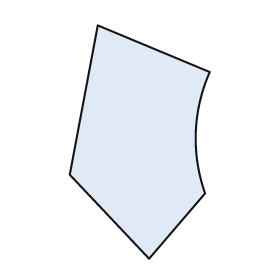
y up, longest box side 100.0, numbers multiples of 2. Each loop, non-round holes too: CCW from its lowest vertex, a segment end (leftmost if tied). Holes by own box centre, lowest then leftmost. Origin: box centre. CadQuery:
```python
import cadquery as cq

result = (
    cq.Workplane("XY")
    .moveTo(4.0, -50.0)
    .lineTo(28.0, -22.0)
    .threePointArc((24.0, 4.0), (30.0, 30.0))
    .lineTo(-18.0, 50.0)
    .lineTo(-30.0, -14.0)
    .close()
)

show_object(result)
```